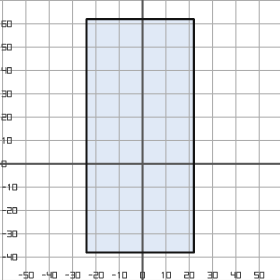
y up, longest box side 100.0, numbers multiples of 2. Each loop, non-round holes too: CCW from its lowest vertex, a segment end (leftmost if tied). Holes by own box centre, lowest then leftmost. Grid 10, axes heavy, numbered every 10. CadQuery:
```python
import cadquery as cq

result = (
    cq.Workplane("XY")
    .moveTo(-24.0, -38.0)
    .lineTo(22.0, -38.0)
    .lineTo(22.0, 62.0)
    .lineTo(-24.0, 62.0)
    .close()
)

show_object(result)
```